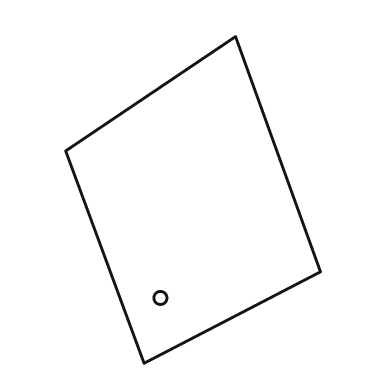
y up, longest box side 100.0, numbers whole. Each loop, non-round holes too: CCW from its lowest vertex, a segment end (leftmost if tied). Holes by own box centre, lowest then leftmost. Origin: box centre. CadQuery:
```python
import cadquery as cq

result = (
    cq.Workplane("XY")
    .moveTo(-15.0, -50.0)
    .lineTo(39.0, -22.0)
    .lineTo(13.0, 50.0)
    .lineTo(-39.0, 15.0)
    .close()
    .moveTo(-10.0, -30.0)
    .circle(2.0)
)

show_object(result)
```